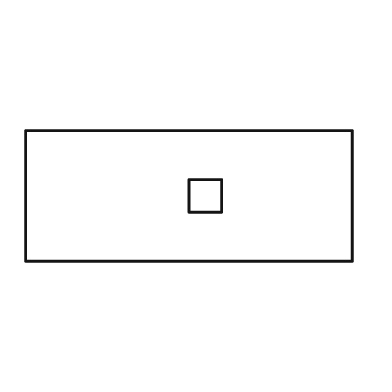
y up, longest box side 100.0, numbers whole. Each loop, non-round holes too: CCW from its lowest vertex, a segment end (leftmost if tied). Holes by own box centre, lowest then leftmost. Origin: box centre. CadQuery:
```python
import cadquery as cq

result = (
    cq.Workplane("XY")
    .moveTo(-50.0, -20.0)
    .lineTo(50.0, -20.0)
    .lineTo(50.0, 20.0)
    .lineTo(-50.0, 20.0)
    .close()
    .moveTo(0.0, -5.0)
    .lineTo(10.0, -5.0)
    .lineTo(10.0, 5.0)
    .lineTo(0.0, 5.0)
    .close()
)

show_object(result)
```